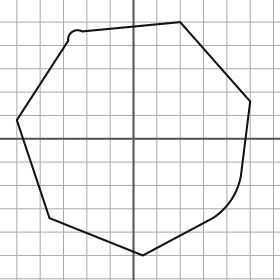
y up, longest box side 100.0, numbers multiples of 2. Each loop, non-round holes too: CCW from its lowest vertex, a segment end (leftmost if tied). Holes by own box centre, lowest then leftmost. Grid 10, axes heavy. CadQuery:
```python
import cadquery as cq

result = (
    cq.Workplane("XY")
    .moveTo(4.0, -50.0)
    .lineTo(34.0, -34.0)
    .threePointArc((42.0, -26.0), (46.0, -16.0))
    .lineTo(50.0, 16.0)
    .lineTo(20.0, 50.0)
    .lineTo(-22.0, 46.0)
    .threePointArc((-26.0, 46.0), (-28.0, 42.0))
    .lineTo(-50.0, 8.0)
    .lineTo(-36.0, -34.0)
    .close()
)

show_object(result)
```